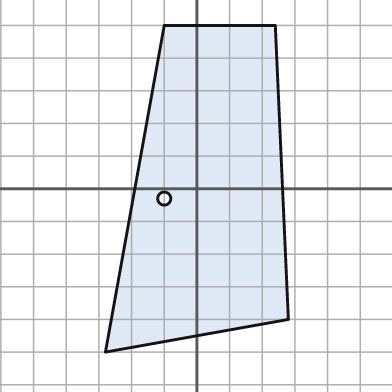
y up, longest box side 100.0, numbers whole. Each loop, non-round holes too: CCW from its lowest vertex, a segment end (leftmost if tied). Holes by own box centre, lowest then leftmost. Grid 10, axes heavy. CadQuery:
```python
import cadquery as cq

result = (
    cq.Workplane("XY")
    .moveTo(-28.0, -50.0)
    .lineTo(28.0, -40.0)
    .lineTo(24.0, 50.0)
    .lineTo(-10.0, 50.0)
    .close()
    .moveTo(-10.0, -3.0)
    .circle(2.0)
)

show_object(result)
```